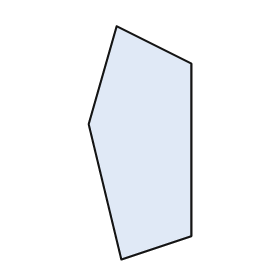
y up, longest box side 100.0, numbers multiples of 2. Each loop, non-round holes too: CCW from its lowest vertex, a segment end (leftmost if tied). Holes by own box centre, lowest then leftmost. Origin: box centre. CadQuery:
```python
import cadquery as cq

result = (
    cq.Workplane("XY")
    .moveTo(-8.0, -50.0)
    .lineTo(22.0, -40.0)
    .lineTo(22.0, 34.0)
    .lineTo(-10.0, 50.0)
    .lineTo(-22.0, 8.0)
    .close()
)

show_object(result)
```